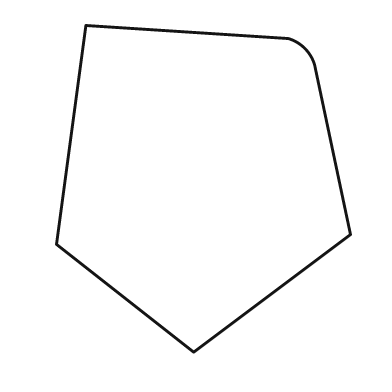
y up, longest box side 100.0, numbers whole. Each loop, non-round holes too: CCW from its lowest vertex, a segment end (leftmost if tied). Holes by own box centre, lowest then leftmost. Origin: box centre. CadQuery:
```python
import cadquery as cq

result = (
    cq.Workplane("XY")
    .moveTo(-3.0, -50.0)
    .lineTo(45.0, -14.0)
    .lineTo(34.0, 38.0)
    .threePointArc((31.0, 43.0), (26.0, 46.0))
    .lineTo(-36.0, 50.0)
    .lineTo(-45.0, -17.0)
    .close()
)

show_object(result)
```